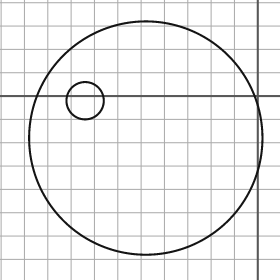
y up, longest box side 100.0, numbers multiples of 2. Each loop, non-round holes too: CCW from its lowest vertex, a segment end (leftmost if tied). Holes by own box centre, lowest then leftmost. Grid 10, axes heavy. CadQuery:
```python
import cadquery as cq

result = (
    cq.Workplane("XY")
    .moveTo(-48.0, -18.0)
    .circle(50.0)
    .moveTo(-74.0, -2.0)
    .circle(8.0)
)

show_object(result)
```